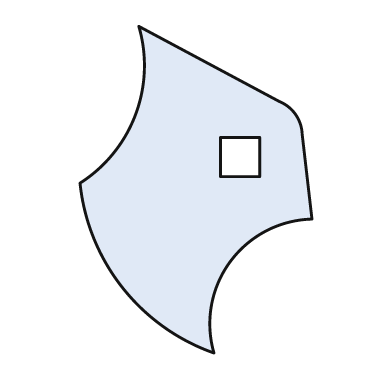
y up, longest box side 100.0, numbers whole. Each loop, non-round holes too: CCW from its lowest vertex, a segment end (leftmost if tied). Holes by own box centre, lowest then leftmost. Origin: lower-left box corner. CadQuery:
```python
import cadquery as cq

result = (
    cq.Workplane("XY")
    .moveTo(41.0, 0.0)
    .threePointArc((46.0, 28.0), (71.0, 41.0))
    .lineTo(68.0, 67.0)
    .threePointArc((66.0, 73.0), (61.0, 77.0))
    .lineTo(18.0, 100.0)
    .threePointArc((17.0, 73.0), (0.0, 52.0))
    .threePointArc((13.0, 20.0), (41.0, 0.0))
    .close()
    .moveTo(43.0, 54.0)
    .lineTo(55.0, 54.0)
    .lineTo(55.0, 66.0)
    .lineTo(43.0, 66.0)
    .close()
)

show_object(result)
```